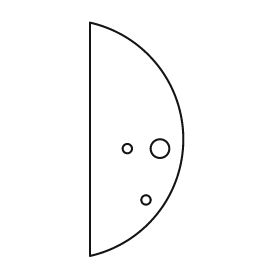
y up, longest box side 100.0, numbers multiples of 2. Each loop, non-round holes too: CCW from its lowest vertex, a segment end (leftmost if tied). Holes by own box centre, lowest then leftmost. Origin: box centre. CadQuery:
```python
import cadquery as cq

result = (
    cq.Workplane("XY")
    .moveTo(-20.0, -50.0)
    .threePointArc((20.0, 0.0), (-20.0, 50.0))
    .close()
    .moveTo(4.0, -26.0)
    .circle(2.0)
    .moveTo(-4.0, -4.0)
    .circle(2.0)
    .moveTo(10.0, -4.0)
    .circle(4.0)
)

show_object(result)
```